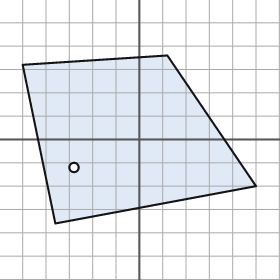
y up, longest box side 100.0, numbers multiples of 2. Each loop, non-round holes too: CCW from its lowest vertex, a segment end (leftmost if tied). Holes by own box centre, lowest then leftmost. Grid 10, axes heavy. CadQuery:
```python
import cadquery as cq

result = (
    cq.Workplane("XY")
    .moveTo(-36.0, -36.0)
    .lineTo(50.0, -20.0)
    .lineTo(12.0, 36.0)
    .lineTo(-50.0, 32.0)
    .close()
    .moveTo(-28.0, -12.0)
    .circle(2.0)
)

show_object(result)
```